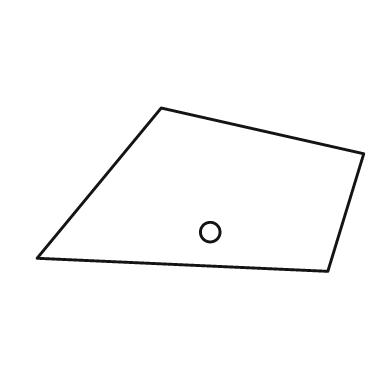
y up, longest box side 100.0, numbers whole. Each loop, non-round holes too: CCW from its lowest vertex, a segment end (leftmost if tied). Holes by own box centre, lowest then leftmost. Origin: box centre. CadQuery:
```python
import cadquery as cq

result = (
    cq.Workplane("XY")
    .moveTo(39.0, -25.0)
    .lineTo(50.0, 11.0)
    .lineTo(-12.0, 25.0)
    .lineTo(-50.0, -21.0)
    .close()
    .moveTo(3.0, -13.0)
    .circle(3.0)
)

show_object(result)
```